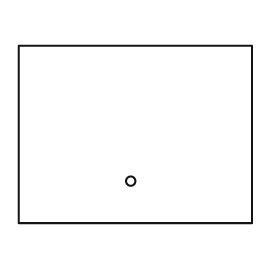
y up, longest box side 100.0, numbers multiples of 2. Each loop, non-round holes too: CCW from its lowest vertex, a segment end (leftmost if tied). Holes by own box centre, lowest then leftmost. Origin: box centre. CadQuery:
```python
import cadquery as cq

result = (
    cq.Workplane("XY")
    .moveTo(-50.0, -38.0)
    .lineTo(50.0, -38.0)
    .lineTo(50.0, 38.0)
    .lineTo(-50.0, 38.0)
    .close()
    .moveTo(-2.0, -20.0)
    .circle(2.0)
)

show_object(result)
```